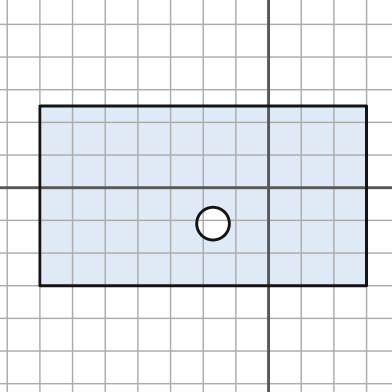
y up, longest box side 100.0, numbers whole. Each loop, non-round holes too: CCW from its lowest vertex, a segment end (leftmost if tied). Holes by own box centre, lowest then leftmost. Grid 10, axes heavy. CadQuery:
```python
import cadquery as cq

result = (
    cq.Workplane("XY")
    .moveTo(-70.0, -30.0)
    .lineTo(30.0, -30.0)
    .lineTo(30.0, 25.0)
    .lineTo(-70.0, 25.0)
    .close()
    .moveTo(-17.0, -11.0)
    .circle(5.0)
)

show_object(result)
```